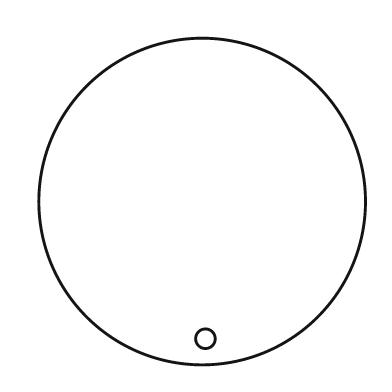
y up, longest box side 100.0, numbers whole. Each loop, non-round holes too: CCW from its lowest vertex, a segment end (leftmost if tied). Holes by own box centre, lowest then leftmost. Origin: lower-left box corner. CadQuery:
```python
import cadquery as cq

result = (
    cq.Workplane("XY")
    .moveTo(50.0, 50.0)
    .circle(50.0)
    .moveTo(51.0, 8.0)
    .circle(3.0)
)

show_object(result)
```